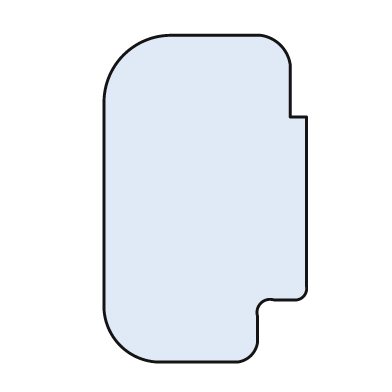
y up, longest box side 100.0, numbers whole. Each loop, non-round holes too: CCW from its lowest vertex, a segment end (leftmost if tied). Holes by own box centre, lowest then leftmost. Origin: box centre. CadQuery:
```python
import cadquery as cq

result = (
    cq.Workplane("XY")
    .moveTo(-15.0, -50.0)
    .lineTo(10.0, -50.0)
    .threePointArc((14.0, -48.0), (16.0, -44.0))
    .lineTo(16.0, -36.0)
    .threePointArc((17.0, -32.0), (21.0, -31.0))
    .lineTo(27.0, -31.0)
    .threePointArc((30.0, -30.0), (31.0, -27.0))
    .lineTo(31.0, 25.0)
    .lineTo(26.0, 25.0)
    .lineTo(26.0, 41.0)
    .threePointArc((23.0, 47.0), (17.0, 50.0))
    .lineTo(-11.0, 50.0)
    .threePointArc((-25.0, 44.0), (-31.0, 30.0))
    .lineTo(-31.0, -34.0)
    .threePointArc((-26.0, -45.0), (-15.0, -50.0))
    .close()
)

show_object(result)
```